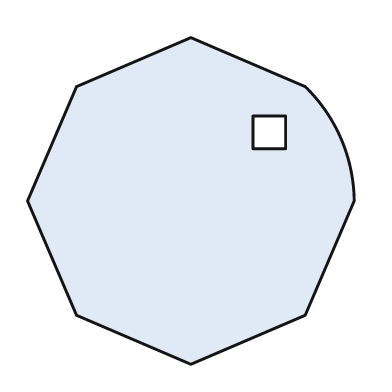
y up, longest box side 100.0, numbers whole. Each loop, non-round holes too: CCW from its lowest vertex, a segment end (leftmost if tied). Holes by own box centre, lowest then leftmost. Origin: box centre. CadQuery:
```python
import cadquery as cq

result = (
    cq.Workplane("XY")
    .moveTo(0.0, -50.0)
    .lineTo(35.0, -35.0)
    .lineTo(50.0, 0.0)
    .threePointArc((46.0, 19.0), (35.0, 35.0))
    .lineTo(0.0, 50.0)
    .lineTo(-35.0, 35.0)
    .lineTo(-50.0, 0.0)
    .lineTo(-35.0, -35.0)
    .close()
    .moveTo(19.0, 16.0)
    .lineTo(29.0, 16.0)
    .lineTo(29.0, 26.0)
    .lineTo(19.0, 26.0)
    .close()
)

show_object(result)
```